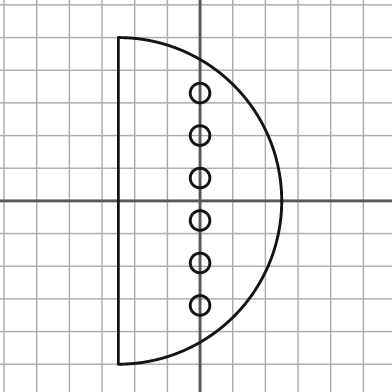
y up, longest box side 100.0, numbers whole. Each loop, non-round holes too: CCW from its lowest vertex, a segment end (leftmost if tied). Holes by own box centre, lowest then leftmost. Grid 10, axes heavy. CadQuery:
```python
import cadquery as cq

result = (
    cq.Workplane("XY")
    .moveTo(-25.0, -50.0)
    .threePointArc((25.0, 0.0), (-25.0, 50.0))
    .close()
    .moveTo(0.0, -32.0)
    .circle(3.0)
    .moveTo(0.0, -19.0)
    .circle(3.0)
    .moveTo(0.0, -6.0)
    .circle(3.0)
    .moveTo(0.0, 7.0)
    .circle(3.0)
    .moveTo(0.0, 20.0)
    .circle(3.0)
    .moveTo(0.0, 33.0)
    .circle(3.0)
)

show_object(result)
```